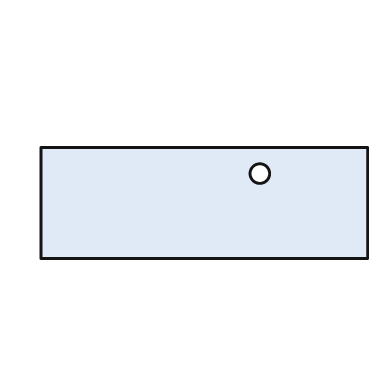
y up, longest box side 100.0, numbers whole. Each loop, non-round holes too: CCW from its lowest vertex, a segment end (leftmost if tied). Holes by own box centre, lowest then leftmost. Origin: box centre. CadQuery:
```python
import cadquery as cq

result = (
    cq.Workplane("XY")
    .moveTo(-50.0, -17.0)
    .lineTo(50.0, -17.0)
    .lineTo(50.0, 17.0)
    .lineTo(-50.0, 17.0)
    .close()
    .moveTo(17.0, 9.0)
    .circle(3.0)
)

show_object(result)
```